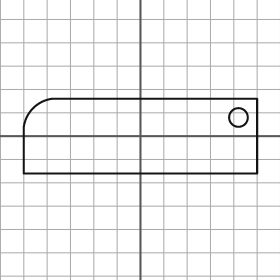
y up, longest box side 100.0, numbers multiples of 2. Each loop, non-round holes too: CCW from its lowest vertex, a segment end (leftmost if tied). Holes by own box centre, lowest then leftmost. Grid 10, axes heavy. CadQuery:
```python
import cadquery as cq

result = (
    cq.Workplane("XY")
    .moveTo(-50.0, -16.0)
    .lineTo(50.0, -16.0)
    .lineTo(50.0, 16.0)
    .lineTo(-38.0, 16.0)
    .threePointArc((-46.0, 12.0), (-50.0, 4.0))
    .close()
    .moveTo(42.0, 8.0)
    .circle(4.0)
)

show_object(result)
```